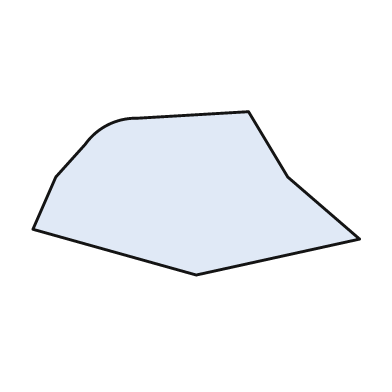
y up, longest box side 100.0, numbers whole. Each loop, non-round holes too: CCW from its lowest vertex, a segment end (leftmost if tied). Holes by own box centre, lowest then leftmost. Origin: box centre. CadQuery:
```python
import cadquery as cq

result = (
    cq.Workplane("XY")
    .moveTo(0.0, -25.0)
    .lineTo(50.0, -14.0)
    .lineTo(28.0, 5.0)
    .lineTo(16.0, 25.0)
    .lineTo(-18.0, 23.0)
    .threePointArc((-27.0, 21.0), (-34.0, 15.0))
    .lineTo(-43.0, 5.0)
    .lineTo(-50.0, -11.0)
    .close()
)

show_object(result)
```